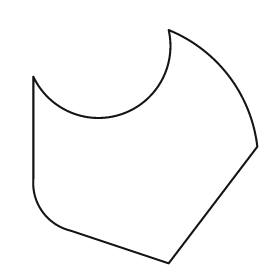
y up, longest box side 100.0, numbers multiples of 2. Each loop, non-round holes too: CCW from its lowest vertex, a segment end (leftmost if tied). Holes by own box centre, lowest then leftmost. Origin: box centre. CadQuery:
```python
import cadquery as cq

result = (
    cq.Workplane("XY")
    .moveTo(10.0, -50.0)
    .lineTo(48.0, 0.0)
    .threePointArc((36.0, 30.0), (10.0, 50.0))
    .threePointArc((-10.0, 14.0), (-48.0, 30.0))
    .lineTo(-48.0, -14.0)
    .threePointArc((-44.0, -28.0), (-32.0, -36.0))
    .close()
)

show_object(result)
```